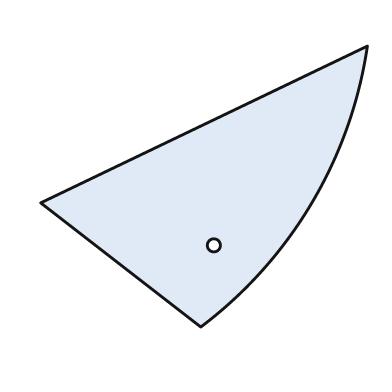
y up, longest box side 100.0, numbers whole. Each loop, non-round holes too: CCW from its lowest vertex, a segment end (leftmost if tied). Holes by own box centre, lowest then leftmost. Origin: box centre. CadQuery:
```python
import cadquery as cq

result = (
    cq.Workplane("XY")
    .moveTo(-1.0, -43.0)
    .threePointArc((33.0, -5.0), (50.0, 43.0))
    .lineTo(-50.0, -5.0)
    .close()
    .moveTo(3.0, -18.0)
    .circle(2.0)
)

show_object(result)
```